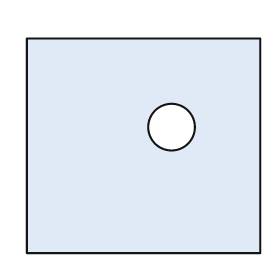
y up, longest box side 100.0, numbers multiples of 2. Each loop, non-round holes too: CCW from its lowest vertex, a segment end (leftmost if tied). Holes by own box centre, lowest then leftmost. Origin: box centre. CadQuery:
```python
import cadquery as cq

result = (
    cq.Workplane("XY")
    .moveTo(-50.0, -46.0)
    .lineTo(50.0, -46.0)
    .lineTo(50.0, 46.0)
    .lineTo(-50.0, 46.0)
    .close()
    .moveTo(12.0, 8.0)
    .circle(10.0)
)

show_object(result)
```